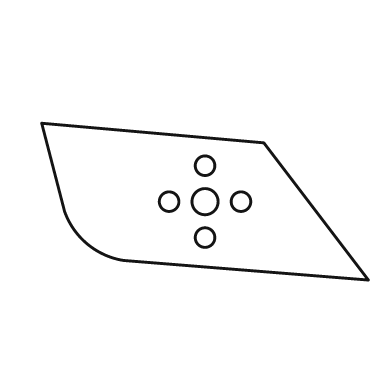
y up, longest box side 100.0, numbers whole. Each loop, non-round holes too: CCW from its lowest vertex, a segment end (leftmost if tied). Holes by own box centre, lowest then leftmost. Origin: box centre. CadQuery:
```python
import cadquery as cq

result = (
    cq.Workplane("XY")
    .moveTo(50.0, -24.0)
    .lineTo(18.0, 18.0)
    .lineTo(-50.0, 24.0)
    .lineTo(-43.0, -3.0)
    .threePointArc((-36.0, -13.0), (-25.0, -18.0))
    .close()
    .moveTo(0.0, -11.0)
    .circle(3.0)
    .moveTo(-11.0, 0.0)
    .circle(3.0)
    .moveTo(0.0, 0.0)
    .circle(4.0)
    .moveTo(11.0, 0.0)
    .circle(3.0)
    .moveTo(0.0, 11.0)
    .circle(3.0)
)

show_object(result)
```